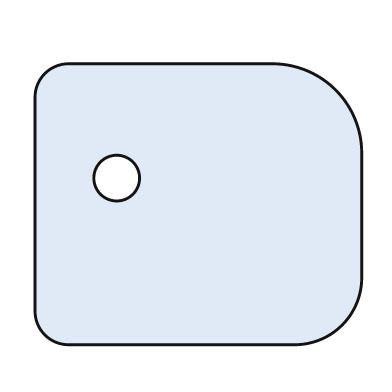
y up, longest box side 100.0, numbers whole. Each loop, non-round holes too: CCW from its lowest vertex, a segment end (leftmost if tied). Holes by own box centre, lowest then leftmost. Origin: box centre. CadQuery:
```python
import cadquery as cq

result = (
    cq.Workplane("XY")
    .moveTo(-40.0, -43.0)
    .lineTo(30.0, -43.0)
    .threePointArc((44.0, -37.0), (50.0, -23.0))
    .lineTo(50.0, 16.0)
    .threePointArc((42.0, 35.0), (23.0, 43.0))
    .lineTo(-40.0, 43.0)
    .threePointArc((-47.0, 40.0), (-50.0, 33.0))
    .lineTo(-50.0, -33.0)
    .threePointArc((-47.0, -40.0), (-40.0, -43.0))
    .close()
    .moveTo(-25.0, 8.0)
    .circle(7.0)
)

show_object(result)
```